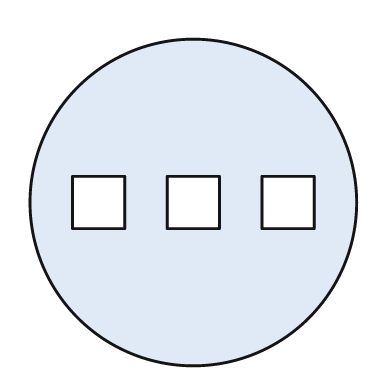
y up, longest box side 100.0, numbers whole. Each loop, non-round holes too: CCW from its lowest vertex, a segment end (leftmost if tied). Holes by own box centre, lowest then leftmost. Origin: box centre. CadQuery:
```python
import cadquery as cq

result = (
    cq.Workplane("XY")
    .moveTo(0.0, 0.0)
    .circle(50.0)
    .moveTo(-37.0, -8.0)
    .lineTo(-21.0, -8.0)
    .lineTo(-21.0, 8.0)
    .lineTo(-37.0, 8.0)
    .close()
    .moveTo(-8.0, -8.0)
    .lineTo(8.0, -8.0)
    .lineTo(8.0, 8.0)
    .lineTo(-8.0, 8.0)
    .close()
    .moveTo(21.0, -8.0)
    .lineTo(37.0, -8.0)
    .lineTo(37.0, 8.0)
    .lineTo(21.0, 8.0)
    .close()
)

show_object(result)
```